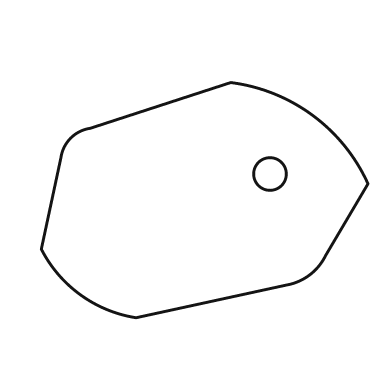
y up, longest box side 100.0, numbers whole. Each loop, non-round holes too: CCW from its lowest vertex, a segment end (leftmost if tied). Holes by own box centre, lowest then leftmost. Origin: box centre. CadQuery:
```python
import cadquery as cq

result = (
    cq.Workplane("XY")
    .moveTo(-21.0, -36.0)
    .lineTo(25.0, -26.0)
    .threePointArc((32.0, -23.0), (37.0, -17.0))
    .lineTo(50.0, 5.0)
    .threePointArc((33.0, 26.0), (8.0, 36.0))
    .lineTo(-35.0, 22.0)
    .threePointArc((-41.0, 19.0), (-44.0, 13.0))
    .lineTo(-50.0, -15.0)
    .threePointArc((-38.0, -29.0), (-21.0, -36.0))
    .close()
    .moveTo(20.0, 8.0)
    .circle(5.0)
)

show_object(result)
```